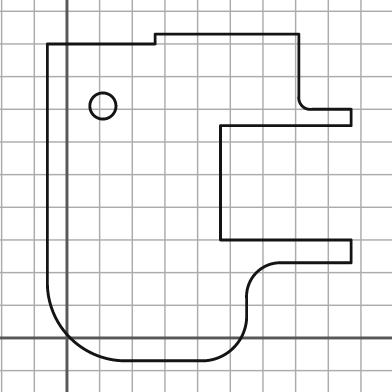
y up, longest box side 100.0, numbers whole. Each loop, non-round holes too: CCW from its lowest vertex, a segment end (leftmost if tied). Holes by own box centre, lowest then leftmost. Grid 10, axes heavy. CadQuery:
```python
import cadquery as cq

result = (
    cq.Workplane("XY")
    .moveTo(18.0, -7.0)
    .lineTo(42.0, -7.0)
    .threePointArc((51.0, -3.0), (55.0, 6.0))
    .lineTo(55.0, 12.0)
    .threePointArc((58.0, 20.0), (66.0, 23.0))
    .lineTo(87.0, 23.0)
    .lineTo(87.0, 30.0)
    .lineTo(47.0, 30.0)
    .lineTo(47.0, 65.0)
    .lineTo(87.0, 65.0)
    .lineTo(87.0, 70.0)
    .lineTo(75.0, 70.0)
    .threePointArc((72.0, 71.0), (71.0, 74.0))
    .lineTo(71.0, 93.0)
    .lineTo(27.0, 93.0)
    .lineTo(27.0, 90.0)
    .lineTo(-6.0, 90.0)
    .lineTo(-6.0, 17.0)
    .threePointArc((1.0, 0.0), (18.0, -7.0))
    .close()
    .moveTo(11.0, 71.0)
    .circle(4.0)
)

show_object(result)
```